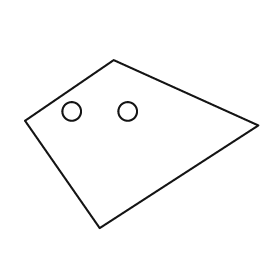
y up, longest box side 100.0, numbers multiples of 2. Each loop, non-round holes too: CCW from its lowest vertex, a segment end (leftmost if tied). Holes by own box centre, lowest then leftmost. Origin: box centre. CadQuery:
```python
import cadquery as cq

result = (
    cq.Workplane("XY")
    .moveTo(-18.0, -36.0)
    .lineTo(50.0, 8.0)
    .lineTo(-12.0, 36.0)
    .lineTo(-50.0, 10.0)
    .close()
    .moveTo(-30.0, 14.0)
    .circle(4.0)
    .moveTo(-6.0, 14.0)
    .circle(4.0)
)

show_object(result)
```